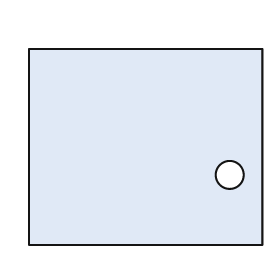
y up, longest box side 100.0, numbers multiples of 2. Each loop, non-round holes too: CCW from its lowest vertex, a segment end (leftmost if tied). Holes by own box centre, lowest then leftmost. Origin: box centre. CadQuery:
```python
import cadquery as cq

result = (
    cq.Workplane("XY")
    .moveTo(-50.0, -42.0)
    .lineTo(50.0, -42.0)
    .lineTo(50.0, 42.0)
    .lineTo(-50.0, 42.0)
    .close()
    .moveTo(36.0, -12.0)
    .circle(6.0)
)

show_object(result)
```